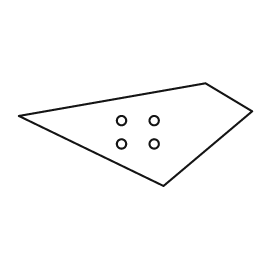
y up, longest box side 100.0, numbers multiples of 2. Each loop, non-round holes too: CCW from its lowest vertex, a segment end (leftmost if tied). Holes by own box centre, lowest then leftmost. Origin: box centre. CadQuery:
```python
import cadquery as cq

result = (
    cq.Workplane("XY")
    .moveTo(12.0, -22.0)
    .lineTo(50.0, 10.0)
    .lineTo(30.0, 22.0)
    .lineTo(-50.0, 8.0)
    .close()
    .moveTo(-6.0, -4.0)
    .circle(2.0)
    .moveTo(8.0, -4.0)
    .circle(2.0)
    .moveTo(-6.0, 6.0)
    .circle(2.0)
    .moveTo(8.0, 6.0)
    .circle(2.0)
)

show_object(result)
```